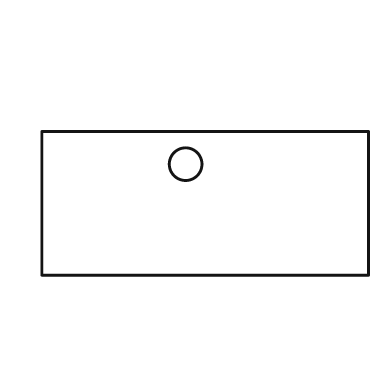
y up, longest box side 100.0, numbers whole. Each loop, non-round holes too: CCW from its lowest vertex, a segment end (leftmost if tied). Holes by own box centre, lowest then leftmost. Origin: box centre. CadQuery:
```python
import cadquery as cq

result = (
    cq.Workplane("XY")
    .moveTo(-50.0, -22.0)
    .lineTo(50.0, -22.0)
    .lineTo(50.0, 22.0)
    .lineTo(-50.0, 22.0)
    .close()
    .moveTo(-6.0, 12.0)
    .circle(5.0)
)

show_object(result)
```